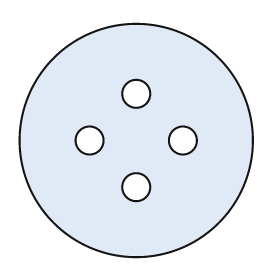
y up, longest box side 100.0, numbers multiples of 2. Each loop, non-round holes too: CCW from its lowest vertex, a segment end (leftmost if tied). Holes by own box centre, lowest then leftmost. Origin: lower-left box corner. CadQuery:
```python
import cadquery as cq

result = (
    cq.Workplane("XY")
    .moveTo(50.0, 50.0)
    .circle(50.0)
    .moveTo(50.0, 30.0)
    .circle(6.0)
    .moveTo(30.0, 50.0)
    .circle(6.0)
    .moveTo(70.0, 50.0)
    .circle(6.0)
    .moveTo(50.0, 70.0)
    .circle(6.0)
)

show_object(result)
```